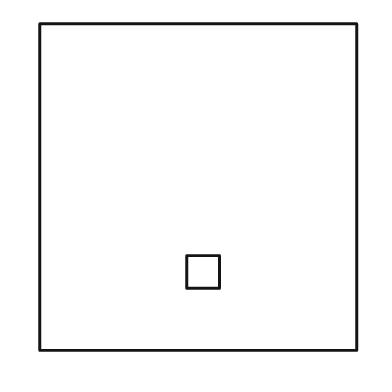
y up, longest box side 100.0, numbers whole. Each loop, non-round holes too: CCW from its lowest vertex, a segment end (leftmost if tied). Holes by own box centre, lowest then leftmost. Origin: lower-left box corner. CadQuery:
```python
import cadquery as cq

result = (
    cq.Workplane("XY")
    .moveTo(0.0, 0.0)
    .lineTo(97.0, 0.0)
    .lineTo(97.0, 100.0)
    .lineTo(0.0, 100.0)
    .close()
    .moveTo(45.0, 19.0)
    .lineTo(55.0, 19.0)
    .lineTo(55.0, 29.0)
    .lineTo(45.0, 29.0)
    .close()
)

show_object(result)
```